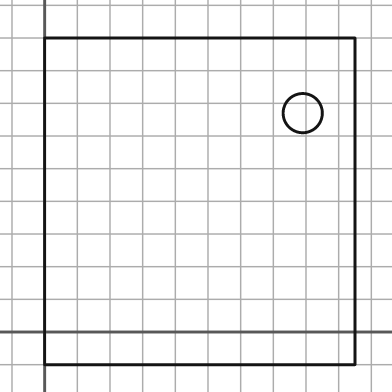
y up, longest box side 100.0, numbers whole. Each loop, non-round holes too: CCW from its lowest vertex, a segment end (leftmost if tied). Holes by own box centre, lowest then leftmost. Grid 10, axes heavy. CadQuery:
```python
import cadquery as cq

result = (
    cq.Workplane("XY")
    .moveTo(0.0, -10.0)
    .lineTo(95.0, -10.0)
    .lineTo(95.0, 90.0)
    .lineTo(0.0, 90.0)
    .close()
    .moveTo(79.0, 67.0)
    .circle(6.0)
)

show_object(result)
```